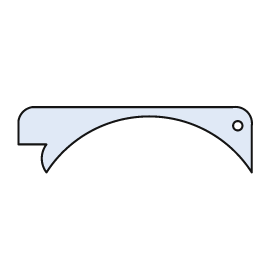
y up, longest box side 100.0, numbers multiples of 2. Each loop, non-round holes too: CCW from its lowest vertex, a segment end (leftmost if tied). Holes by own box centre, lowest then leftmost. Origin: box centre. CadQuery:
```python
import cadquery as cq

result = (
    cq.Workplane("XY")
    .moveTo(-38.0, -14.0)
    .threePointArc((6.0, 10.0), (50.0, -14.0))
    .lineTo(50.0, 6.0)
    .threePointArc((48.0, 12.0), (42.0, 14.0))
    .lineTo(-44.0, 14.0)
    .threePointArc((-48.0, 12.0), (-50.0, 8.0))
    .lineTo(-50.0, -2.0)
    .lineTo(-38.0, -2.0)
    .threePointArc((-40.0, -8.0), (-38.0, -14.0))
    .close()
    .moveTo(44.0, 6.0)
    .circle(2.0)
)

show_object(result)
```